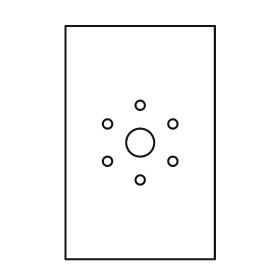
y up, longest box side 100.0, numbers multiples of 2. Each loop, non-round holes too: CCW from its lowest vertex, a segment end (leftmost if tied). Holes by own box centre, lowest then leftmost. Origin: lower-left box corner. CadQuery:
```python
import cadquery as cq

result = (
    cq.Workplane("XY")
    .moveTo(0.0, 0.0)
    .lineTo(64.0, 0.0)
    .lineTo(64.0, 100.0)
    .lineTo(0.0, 100.0)
    .close()
    .moveTo(32.0, 34.0)
    .circle(2.0)
    .moveTo(18.0, 42.0)
    .circle(2.0)
    .moveTo(46.0, 42.0)
    .circle(2.0)
    .moveTo(32.0, 50.0)
    .circle(6.0)
    .moveTo(18.0, 58.0)
    .circle(2.0)
    .moveTo(46.0, 58.0)
    .circle(2.0)
    .moveTo(32.0, 66.0)
    .circle(2.0)
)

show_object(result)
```